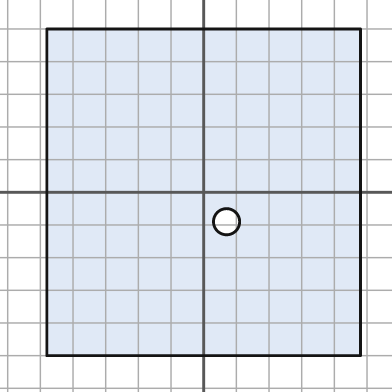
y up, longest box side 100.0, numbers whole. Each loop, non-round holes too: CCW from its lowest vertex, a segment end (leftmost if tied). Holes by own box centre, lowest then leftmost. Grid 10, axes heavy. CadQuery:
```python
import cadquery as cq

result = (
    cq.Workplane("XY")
    .moveTo(-48.0, -50.0)
    .lineTo(48.0, -50.0)
    .lineTo(48.0, 50.0)
    .lineTo(-48.0, 50.0)
    .close()
    .moveTo(7.0, -9.0)
    .circle(4.0)
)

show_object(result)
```